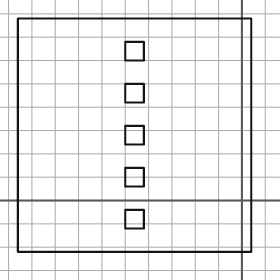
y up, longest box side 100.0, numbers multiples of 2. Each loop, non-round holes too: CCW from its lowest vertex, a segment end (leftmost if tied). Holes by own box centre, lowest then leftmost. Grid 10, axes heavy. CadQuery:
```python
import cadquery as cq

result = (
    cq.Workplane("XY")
    .moveTo(-96.0, -22.0)
    .lineTo(4.0, -22.0)
    .lineTo(4.0, 78.0)
    .lineTo(-96.0, 78.0)
    .close()
    .moveTo(-50.0, -12.0)
    .lineTo(-42.0, -12.0)
    .lineTo(-42.0, -4.0)
    .lineTo(-50.0, -4.0)
    .close()
    .moveTo(-50.0, 6.0)
    .lineTo(-42.0, 6.0)
    .lineTo(-42.0, 14.0)
    .lineTo(-50.0, 14.0)
    .close()
    .moveTo(-50.0, 24.0)
    .lineTo(-42.0, 24.0)
    .lineTo(-42.0, 32.0)
    .lineTo(-50.0, 32.0)
    .close()
    .moveTo(-50.0, 42.0)
    .lineTo(-42.0, 42.0)
    .lineTo(-42.0, 50.0)
    .lineTo(-50.0, 50.0)
    .close()
    .moveTo(-50.0, 60.0)
    .lineTo(-42.0, 60.0)
    .lineTo(-42.0, 68.0)
    .lineTo(-50.0, 68.0)
    .close()
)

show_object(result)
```